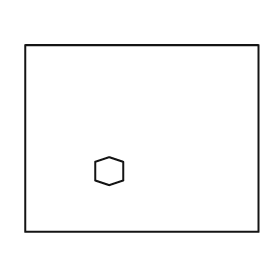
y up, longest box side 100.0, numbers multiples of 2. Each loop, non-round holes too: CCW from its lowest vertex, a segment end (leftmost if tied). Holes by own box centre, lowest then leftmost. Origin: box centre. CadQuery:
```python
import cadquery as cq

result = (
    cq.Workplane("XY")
    .moveTo(-50.0, -40.0)
    .lineTo(50.0, -40.0)
    .lineTo(50.0, 40.0)
    .lineTo(-50.0, 40.0)
    .close()
    .moveTo(-14.0, -20.0)
    .lineTo(-8.0, -18.0)
    .lineTo(-8.0, -10.0)
    .lineTo(-14.0, -8.0)
    .lineTo(-20.0, -10.0)
    .lineTo(-20.0, -18.0)
    .close()
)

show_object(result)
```